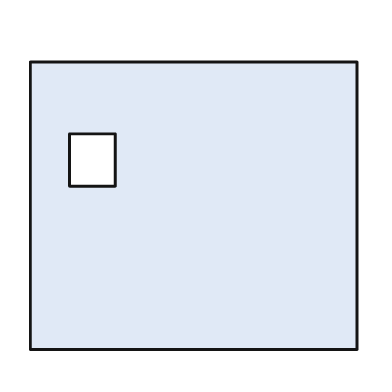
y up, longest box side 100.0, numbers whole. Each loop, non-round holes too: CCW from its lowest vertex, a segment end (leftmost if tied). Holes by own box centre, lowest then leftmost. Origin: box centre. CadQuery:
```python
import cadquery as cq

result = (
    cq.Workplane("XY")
    .moveTo(-50.0, -44.0)
    .lineTo(50.0, -44.0)
    .lineTo(50.0, 44.0)
    .lineTo(-50.0, 44.0)
    .close()
    .moveTo(-38.0, 6.0)
    .lineTo(-24.0, 6.0)
    .lineTo(-24.0, 22.0)
    .lineTo(-38.0, 22.0)
    .close()
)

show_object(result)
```